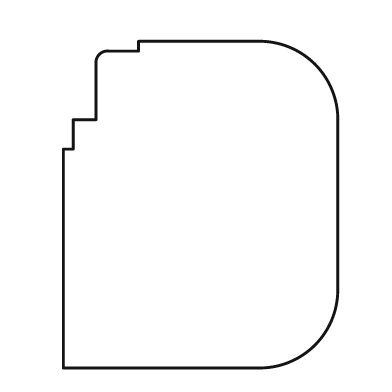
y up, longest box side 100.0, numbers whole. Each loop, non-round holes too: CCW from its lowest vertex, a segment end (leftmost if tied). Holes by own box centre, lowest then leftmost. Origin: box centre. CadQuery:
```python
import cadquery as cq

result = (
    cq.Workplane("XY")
    .moveTo(-42.0, -50.0)
    .lineTo(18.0, -50.0)
    .threePointArc((35.0, -43.0), (42.0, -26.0))
    .lineTo(42.0, 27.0)
    .threePointArc((35.0, 43.0), (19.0, 50.0))
    .lineTo(-19.0, 50.0)
    .lineTo(-19.0, 47.0)
    .lineTo(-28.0, 47.0)
    .threePointArc((-31.0, 46.0), (-32.0, 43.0))
    .lineTo(-32.0, 26.0)
    .lineTo(-39.0, 26.0)
    .lineTo(-39.0, 17.0)
    .lineTo(-42.0, 17.0)
    .close()
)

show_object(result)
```